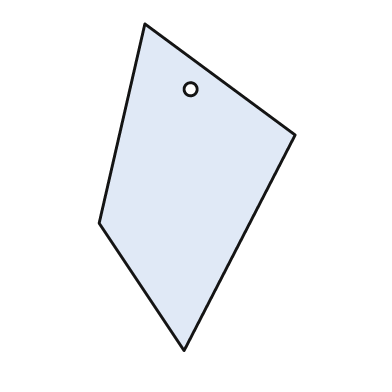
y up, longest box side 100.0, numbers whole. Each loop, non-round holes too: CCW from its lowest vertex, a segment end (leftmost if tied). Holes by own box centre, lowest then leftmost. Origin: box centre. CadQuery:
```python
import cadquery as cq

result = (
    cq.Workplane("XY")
    .moveTo(-4.0, -50.0)
    .lineTo(30.0, 16.0)
    .lineTo(-16.0, 50.0)
    .lineTo(-30.0, -11.0)
    .close()
    .moveTo(-2.0, 30.0)
    .circle(2.0)
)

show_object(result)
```